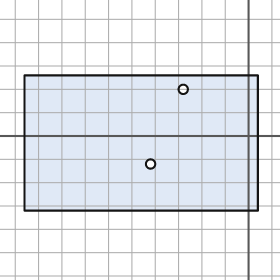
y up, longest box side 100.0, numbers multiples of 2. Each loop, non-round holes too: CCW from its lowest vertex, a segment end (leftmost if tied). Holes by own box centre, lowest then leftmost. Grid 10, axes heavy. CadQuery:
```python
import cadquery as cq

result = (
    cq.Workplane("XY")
    .moveTo(-96.0, -32.0)
    .lineTo(4.0, -32.0)
    .lineTo(4.0, 26.0)
    .lineTo(-96.0, 26.0)
    .close()
    .moveTo(-42.0, -12.0)
    .circle(2.0)
    .moveTo(-28.0, 20.0)
    .circle(2.0)
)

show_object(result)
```